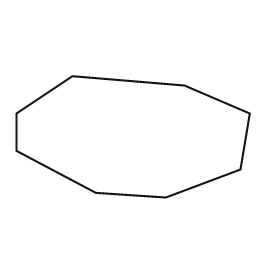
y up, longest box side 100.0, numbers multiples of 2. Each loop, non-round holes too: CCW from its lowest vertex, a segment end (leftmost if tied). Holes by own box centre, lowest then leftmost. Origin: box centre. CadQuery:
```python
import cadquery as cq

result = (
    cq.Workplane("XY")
    .moveTo(14.0, -26.0)
    .lineTo(46.0, -14.0)
    .lineTo(50.0, 10.0)
    .lineTo(22.0, 22.0)
    .lineTo(-26.0, 26.0)
    .lineTo(-50.0, 10.0)
    .lineTo(-50.0, -6.0)
    .lineTo(-16.0, -24.0)
    .close()
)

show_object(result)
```